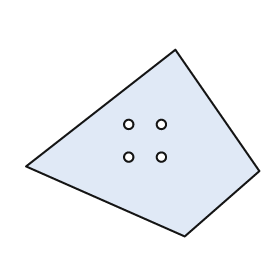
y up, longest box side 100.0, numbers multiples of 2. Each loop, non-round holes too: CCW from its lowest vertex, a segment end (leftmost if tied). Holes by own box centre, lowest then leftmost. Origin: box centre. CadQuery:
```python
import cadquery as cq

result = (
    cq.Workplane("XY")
    .moveTo(18.0, -40.0)
    .lineTo(50.0, -12.0)
    .lineTo(14.0, 40.0)
    .lineTo(-50.0, -10.0)
    .close()
    .moveTo(-6.0, -6.0)
    .circle(2.0)
    .moveTo(8.0, -6.0)
    .circle(2.0)
    .moveTo(-6.0, 8.0)
    .circle(2.0)
    .moveTo(8.0, 8.0)
    .circle(2.0)
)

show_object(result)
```